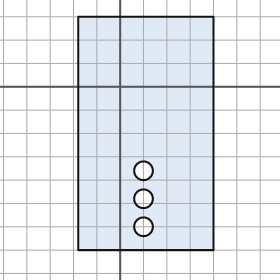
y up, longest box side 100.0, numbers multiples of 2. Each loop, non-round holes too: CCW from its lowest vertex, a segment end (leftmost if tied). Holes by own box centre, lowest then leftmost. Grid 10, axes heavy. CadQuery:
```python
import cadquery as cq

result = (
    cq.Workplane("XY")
    .moveTo(-18.0, -70.0)
    .lineTo(40.0, -70.0)
    .lineTo(40.0, 30.0)
    .lineTo(-18.0, 30.0)
    .close()
    .moveTo(10.0, -60.0)
    .circle(4.0)
    .moveTo(10.0, -48.0)
    .circle(4.0)
    .moveTo(10.0, -36.0)
    .circle(4.0)
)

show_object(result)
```